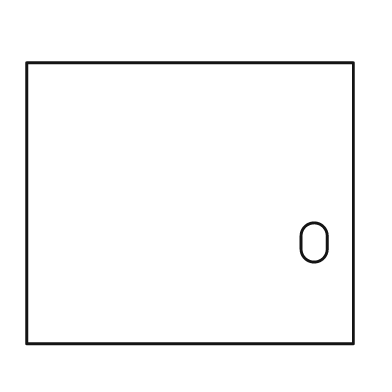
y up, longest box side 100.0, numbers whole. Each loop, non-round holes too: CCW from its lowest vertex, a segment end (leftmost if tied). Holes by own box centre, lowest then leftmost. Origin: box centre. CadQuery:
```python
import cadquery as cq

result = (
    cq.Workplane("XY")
    .moveTo(-50.0, -43.0)
    .lineTo(50.0, -43.0)
    .lineTo(50.0, 43.0)
    .lineTo(-50.0, 43.0)
    .close()
    .moveTo(34.0, -14.0)
    .threePointArc((38.0, -18.0), (42.0, -14.0))
    .lineTo(42.0, -10.0)
    .threePointArc((38.0, -6.0), (34.0, -10.0))
    .close()
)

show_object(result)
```